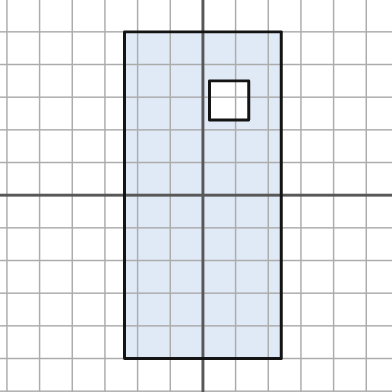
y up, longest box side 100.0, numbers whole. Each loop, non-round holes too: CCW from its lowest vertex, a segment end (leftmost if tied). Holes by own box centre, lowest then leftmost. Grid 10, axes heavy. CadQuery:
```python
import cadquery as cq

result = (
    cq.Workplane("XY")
    .moveTo(-24.0, -50.0)
    .lineTo(24.0, -50.0)
    .lineTo(24.0, 50.0)
    .lineTo(-24.0, 50.0)
    .close()
    .moveTo(2.0, 23.0)
    .lineTo(14.0, 23.0)
    .lineTo(14.0, 35.0)
    .lineTo(2.0, 35.0)
    .close()
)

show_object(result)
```